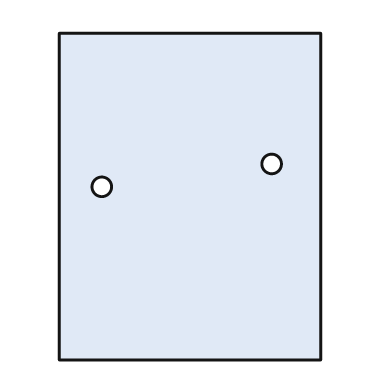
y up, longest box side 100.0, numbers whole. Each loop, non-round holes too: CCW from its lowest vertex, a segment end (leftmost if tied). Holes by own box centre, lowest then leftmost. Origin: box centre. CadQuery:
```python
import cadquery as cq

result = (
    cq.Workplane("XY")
    .moveTo(-40.0, -50.0)
    .lineTo(40.0, -50.0)
    .lineTo(40.0, 50.0)
    .lineTo(-40.0, 50.0)
    .close()
    .moveTo(-27.0, 3.0)
    .circle(3.0)
    .moveTo(25.0, 10.0)
    .circle(3.0)
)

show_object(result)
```